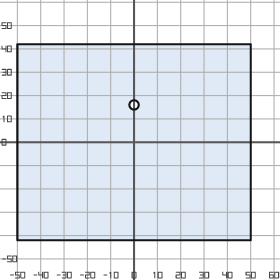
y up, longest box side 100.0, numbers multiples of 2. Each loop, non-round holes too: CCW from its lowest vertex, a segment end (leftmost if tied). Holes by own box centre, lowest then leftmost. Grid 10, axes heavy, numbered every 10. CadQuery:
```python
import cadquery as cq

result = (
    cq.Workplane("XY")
    .moveTo(-50.0, -42.0)
    .lineTo(50.0, -42.0)
    .lineTo(50.0, 42.0)
    .lineTo(-50.0, 42.0)
    .close()
    .moveTo(0.0, 16.0)
    .circle(2.0)
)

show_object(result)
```